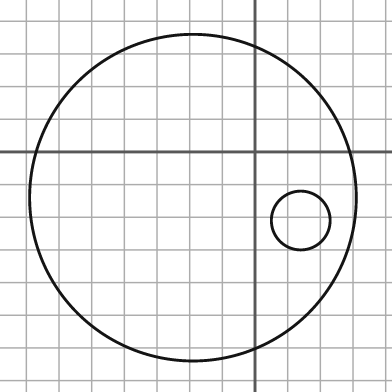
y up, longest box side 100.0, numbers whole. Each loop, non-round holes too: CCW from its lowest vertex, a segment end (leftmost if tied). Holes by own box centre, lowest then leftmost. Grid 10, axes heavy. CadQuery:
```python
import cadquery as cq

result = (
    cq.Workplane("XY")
    .moveTo(-19.0, -14.0)
    .circle(50.0)
    .moveTo(14.0, -21.0)
    .circle(9.0)
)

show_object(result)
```